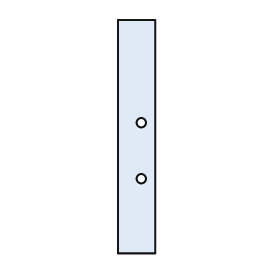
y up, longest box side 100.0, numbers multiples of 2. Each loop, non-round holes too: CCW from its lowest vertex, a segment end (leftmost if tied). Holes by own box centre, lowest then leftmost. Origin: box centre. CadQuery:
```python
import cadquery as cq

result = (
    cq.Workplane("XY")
    .moveTo(-8.0, -50.0)
    .lineTo(8.0, -50.0)
    .lineTo(8.0, 50.0)
    .lineTo(-8.0, 50.0)
    .close()
    .moveTo(2.0, -18.0)
    .circle(2.0)
    .moveTo(2.0, 6.0)
    .circle(2.0)
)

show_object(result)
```